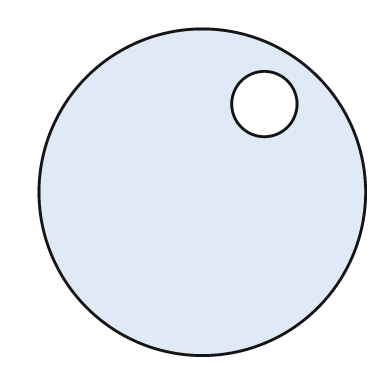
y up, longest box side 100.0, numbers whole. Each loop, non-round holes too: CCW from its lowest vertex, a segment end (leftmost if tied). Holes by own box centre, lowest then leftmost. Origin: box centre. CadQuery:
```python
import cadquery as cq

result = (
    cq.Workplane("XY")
    .moveTo(0.0, 0.0)
    .circle(50.0)
    .moveTo(19.0, 27.0)
    .circle(10.0)
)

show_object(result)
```